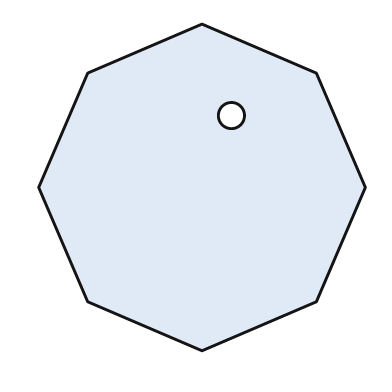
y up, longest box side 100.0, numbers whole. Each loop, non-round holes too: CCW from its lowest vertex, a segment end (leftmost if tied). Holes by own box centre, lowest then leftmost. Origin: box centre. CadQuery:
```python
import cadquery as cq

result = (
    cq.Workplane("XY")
    .moveTo(0.0, -50.0)
    .lineTo(35.0, -35.0)
    .lineTo(50.0, 0.0)
    .lineTo(35.0, 35.0)
    .lineTo(0.0, 50.0)
    .lineTo(-35.0, 35.0)
    .lineTo(-50.0, 0.0)
    .lineTo(-35.0, -35.0)
    .close()
    .moveTo(9.0, 22.0)
    .circle(4.0)
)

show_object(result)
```